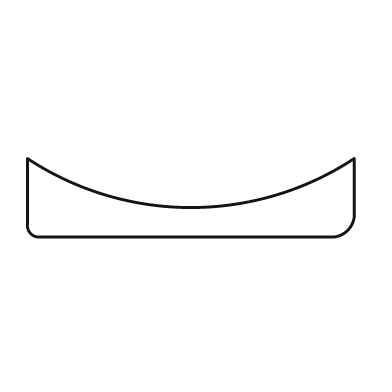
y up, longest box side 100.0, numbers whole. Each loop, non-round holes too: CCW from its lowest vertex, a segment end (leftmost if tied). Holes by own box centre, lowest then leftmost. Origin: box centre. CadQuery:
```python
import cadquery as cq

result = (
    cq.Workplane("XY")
    .moveTo(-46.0, -12.0)
    .lineTo(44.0, -12.0)
    .threePointArc((48.0, -10.0), (50.0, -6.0))
    .lineTo(50.0, 12.0)
    .threePointArc((0.0, -3.0), (-50.0, 12.0))
    .lineTo(-50.0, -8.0)
    .threePointArc((-49.0, -11.0), (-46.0, -12.0))
    .close()
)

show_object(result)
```